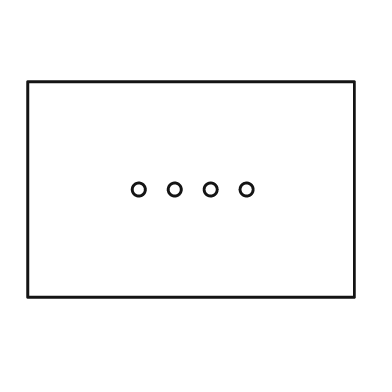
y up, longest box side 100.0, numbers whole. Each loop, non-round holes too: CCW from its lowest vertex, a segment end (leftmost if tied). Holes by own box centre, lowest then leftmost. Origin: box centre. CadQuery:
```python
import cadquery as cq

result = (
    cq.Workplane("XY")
    .moveTo(-50.0, -33.0)
    .lineTo(50.0, -33.0)
    .lineTo(50.0, 33.0)
    .lineTo(-50.0, 33.0)
    .close()
    .moveTo(-16.0, 0.0)
    .circle(2.0)
    .moveTo(-5.0, 0.0)
    .circle(2.0)
    .moveTo(6.0, 0.0)
    .circle(2.0)
    .moveTo(17.0, 0.0)
    .circle(2.0)
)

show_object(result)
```